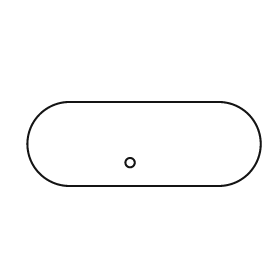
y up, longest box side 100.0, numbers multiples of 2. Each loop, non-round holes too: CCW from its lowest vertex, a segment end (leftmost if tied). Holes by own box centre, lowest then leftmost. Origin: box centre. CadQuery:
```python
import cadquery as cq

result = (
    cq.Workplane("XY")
    .moveTo(-32.0, -18.0)
    .lineTo(32.0, -18.0)
    .threePointArc((50.0, 0.0), (32.0, 18.0))
    .lineTo(-32.0, 18.0)
    .threePointArc((-50.0, 0.0), (-32.0, -18.0))
    .close()
    .moveTo(-6.0, -8.0)
    .circle(2.0)
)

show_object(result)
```